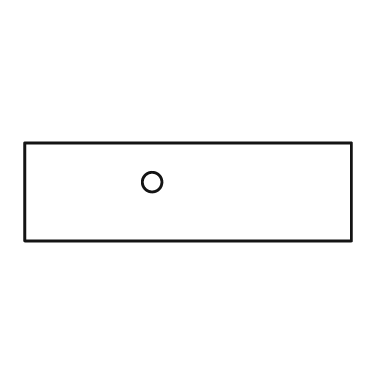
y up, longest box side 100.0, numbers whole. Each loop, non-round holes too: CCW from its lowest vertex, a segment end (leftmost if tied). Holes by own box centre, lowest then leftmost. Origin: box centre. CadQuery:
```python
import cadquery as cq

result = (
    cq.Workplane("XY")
    .moveTo(-50.0, -15.0)
    .lineTo(50.0, -15.0)
    .lineTo(50.0, 15.0)
    .lineTo(-50.0, 15.0)
    .close()
    .moveTo(-11.0, 3.0)
    .circle(3.0)
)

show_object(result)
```